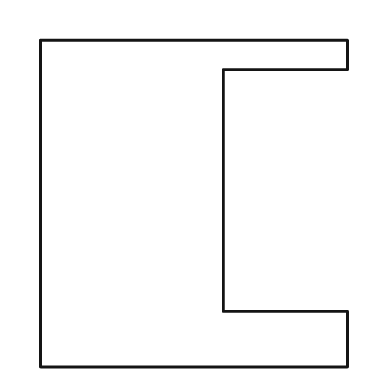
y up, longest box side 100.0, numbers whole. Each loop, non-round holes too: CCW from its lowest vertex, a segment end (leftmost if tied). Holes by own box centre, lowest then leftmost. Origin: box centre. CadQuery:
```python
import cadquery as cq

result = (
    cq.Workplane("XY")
    .moveTo(-47.0, -50.0)
    .lineTo(47.0, -50.0)
    .lineTo(47.0, -33.0)
    .lineTo(9.0, -33.0)
    .lineTo(9.0, 41.0)
    .lineTo(47.0, 41.0)
    .lineTo(47.0, 50.0)
    .lineTo(-47.0, 50.0)
    .close()
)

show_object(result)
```